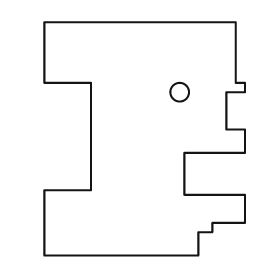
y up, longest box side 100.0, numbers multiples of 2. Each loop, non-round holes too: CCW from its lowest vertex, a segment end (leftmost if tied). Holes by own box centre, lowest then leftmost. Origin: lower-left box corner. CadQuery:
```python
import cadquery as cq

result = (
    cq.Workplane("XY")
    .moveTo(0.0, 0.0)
    .lineTo(66.0, 0.0)
    .lineTo(66.0, 10.0)
    .lineTo(72.0, 10.0)
    .lineTo(72.0, 14.0)
    .lineTo(86.0, 14.0)
    .lineTo(86.0, 26.0)
    .lineTo(60.0, 26.0)
    .lineTo(60.0, 44.0)
    .lineTo(86.0, 44.0)
    .lineTo(86.0, 54.0)
    .lineTo(78.0, 54.0)
    .lineTo(78.0, 70.0)
    .lineTo(86.0, 70.0)
    .lineTo(86.0, 74.0)
    .lineTo(82.0, 74.0)
    .lineTo(82.0, 100.0)
    .lineTo(0.0, 100.0)
    .lineTo(0.0, 74.0)
    .lineTo(20.0, 74.0)
    .lineTo(20.0, 28.0)
    .lineTo(0.0, 28.0)
    .close()
    .moveTo(58.0, 70.0)
    .circle(4.0)
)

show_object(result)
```